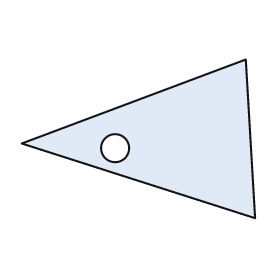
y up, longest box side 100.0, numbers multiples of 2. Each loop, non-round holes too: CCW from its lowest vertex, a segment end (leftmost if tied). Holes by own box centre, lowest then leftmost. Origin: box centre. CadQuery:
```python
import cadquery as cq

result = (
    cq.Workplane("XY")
    .moveTo(50.0, -34.0)
    .lineTo(46.0, 34.0)
    .lineTo(-50.0, -2.0)
    .close()
    .moveTo(-10.0, -4.0)
    .circle(6.0)
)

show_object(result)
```